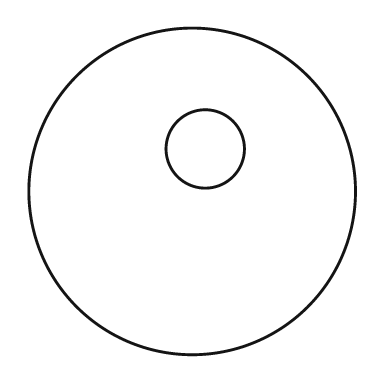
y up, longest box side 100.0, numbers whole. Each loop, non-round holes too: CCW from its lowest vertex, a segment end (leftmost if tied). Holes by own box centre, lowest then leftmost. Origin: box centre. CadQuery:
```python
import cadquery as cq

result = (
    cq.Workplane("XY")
    .moveTo(0.0, 0.0)
    .circle(50.0)
    .moveTo(4.0, 13.0)
    .circle(12.0)
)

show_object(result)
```